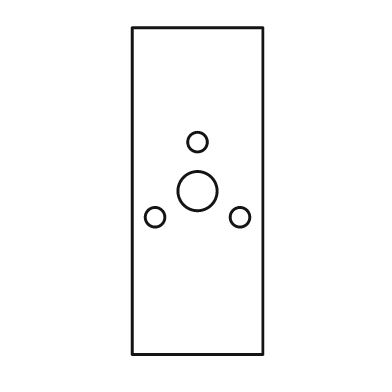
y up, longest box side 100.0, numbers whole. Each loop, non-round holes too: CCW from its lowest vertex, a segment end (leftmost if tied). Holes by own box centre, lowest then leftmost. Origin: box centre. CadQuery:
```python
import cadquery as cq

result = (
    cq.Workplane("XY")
    .moveTo(-20.0, -50.0)
    .lineTo(20.0, -50.0)
    .lineTo(20.0, 50.0)
    .lineTo(-20.0, 50.0)
    .close()
    .moveTo(-13.0, -8.0)
    .circle(3.0)
    .moveTo(13.0, -8.0)
    .circle(3.0)
    .moveTo(0.0, 0.0)
    .circle(6.0)
    .moveTo(0.0, 15.0)
    .circle(3.0)
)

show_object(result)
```